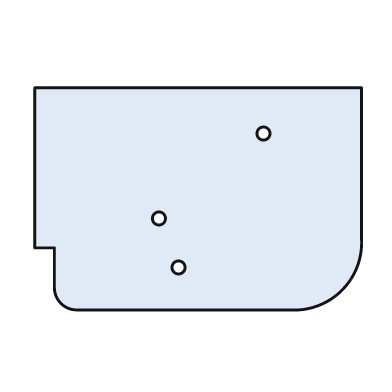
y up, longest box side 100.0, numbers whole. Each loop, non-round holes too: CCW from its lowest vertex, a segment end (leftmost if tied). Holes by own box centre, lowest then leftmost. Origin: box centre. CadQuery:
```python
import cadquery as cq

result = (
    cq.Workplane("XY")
    .moveTo(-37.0, -34.0)
    .lineTo(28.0, -34.0)
    .threePointArc((44.0, -28.0), (50.0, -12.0))
    .lineTo(50.0, 34.0)
    .lineTo(-50.0, 34.0)
    .lineTo(-50.0, -15.0)
    .lineTo(-44.0, -15.0)
    .lineTo(-44.0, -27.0)
    .threePointArc((-42.0, -32.0), (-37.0, -34.0))
    .close()
    .moveTo(-6.0, -21.0)
    .circle(2.0)
    .moveTo(-12.0, -6.0)
    .circle(2.0)
    .moveTo(20.0, 20.0)
    .circle(2.0)
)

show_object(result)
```